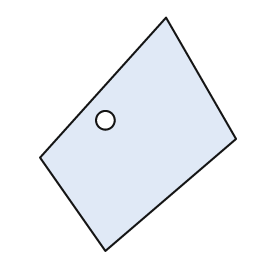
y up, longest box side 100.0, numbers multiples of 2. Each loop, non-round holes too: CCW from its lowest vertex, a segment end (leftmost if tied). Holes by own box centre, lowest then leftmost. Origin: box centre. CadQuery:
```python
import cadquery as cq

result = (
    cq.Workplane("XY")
    .moveTo(-14.0, -50.0)
    .lineTo(42.0, -2.0)
    .lineTo(12.0, 50.0)
    .lineTo(-42.0, -10.0)
    .close()
    .moveTo(-14.0, 6.0)
    .circle(4.0)
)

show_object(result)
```